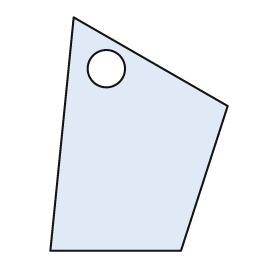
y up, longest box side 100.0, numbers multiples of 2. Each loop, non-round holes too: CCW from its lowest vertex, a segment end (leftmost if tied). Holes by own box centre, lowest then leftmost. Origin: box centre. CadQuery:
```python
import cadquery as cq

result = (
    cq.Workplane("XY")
    .moveTo(-38.0, -50.0)
    .lineTo(18.0, -50.0)
    .lineTo(38.0, 12.0)
    .lineTo(-28.0, 50.0)
    .close()
    .moveTo(-14.0, 28.0)
    .circle(8.0)
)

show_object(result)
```